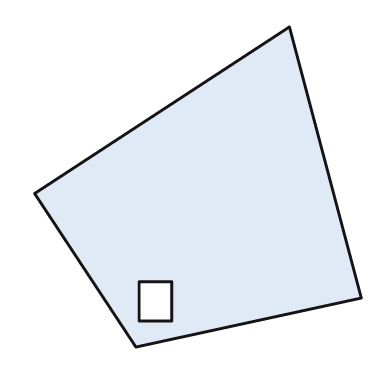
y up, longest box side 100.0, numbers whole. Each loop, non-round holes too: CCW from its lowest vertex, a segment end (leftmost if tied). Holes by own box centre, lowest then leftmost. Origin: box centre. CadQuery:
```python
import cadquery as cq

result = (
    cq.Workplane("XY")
    .moveTo(-19.0, -49.0)
    .lineTo(50.0, -34.0)
    .lineTo(28.0, 49.0)
    .lineTo(-50.0, -2.0)
    .close()
    .moveTo(-18.0, -41.0)
    .lineTo(-8.0, -41.0)
    .lineTo(-8.0, -29.0)
    .lineTo(-18.0, -29.0)
    .close()
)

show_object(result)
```